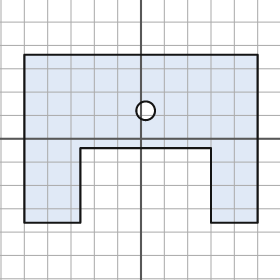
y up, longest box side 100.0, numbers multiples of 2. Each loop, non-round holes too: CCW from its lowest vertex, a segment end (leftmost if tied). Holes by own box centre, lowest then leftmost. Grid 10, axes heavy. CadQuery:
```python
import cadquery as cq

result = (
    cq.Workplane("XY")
    .moveTo(-50.0, -36.0)
    .lineTo(-26.0, -36.0)
    .lineTo(-26.0, -4.0)
    .lineTo(30.0, -4.0)
    .lineTo(30.0, -36.0)
    .lineTo(50.0, -36.0)
    .lineTo(50.0, 36.0)
    .lineTo(-50.0, 36.0)
    .close()
    .moveTo(2.0, 12.0)
    .circle(4.0)
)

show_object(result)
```